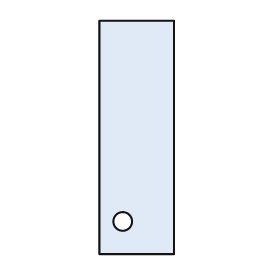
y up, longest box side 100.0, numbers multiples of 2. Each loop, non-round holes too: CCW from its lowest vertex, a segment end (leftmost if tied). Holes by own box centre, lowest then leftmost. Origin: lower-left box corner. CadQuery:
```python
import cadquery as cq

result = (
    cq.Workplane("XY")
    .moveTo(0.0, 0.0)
    .lineTo(32.0, 0.0)
    .lineTo(32.0, 100.0)
    .lineTo(0.0, 100.0)
    .close()
    .moveTo(10.0, 14.0)
    .circle(4.0)
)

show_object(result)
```